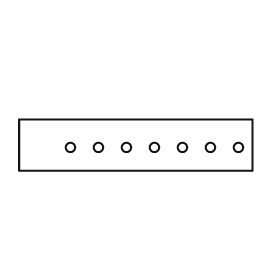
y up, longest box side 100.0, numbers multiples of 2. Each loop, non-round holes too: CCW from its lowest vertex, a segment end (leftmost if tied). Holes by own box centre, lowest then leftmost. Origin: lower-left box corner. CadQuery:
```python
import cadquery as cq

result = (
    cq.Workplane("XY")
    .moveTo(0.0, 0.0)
    .lineTo(100.0, 0.0)
    .lineTo(100.0, 22.0)
    .lineTo(0.0, 22.0)
    .close()
    .moveTo(22.0, 10.0)
    .circle(2.0)
    .moveTo(34.0, 10.0)
    .circle(2.0)
    .moveTo(46.0, 10.0)
    .circle(2.0)
    .moveTo(58.0, 10.0)
    .circle(2.0)
    .moveTo(70.0, 10.0)
    .circle(2.0)
    .moveTo(82.0, 10.0)
    .circle(2.0)
    .moveTo(94.0, 10.0)
    .circle(2.0)
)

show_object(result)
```